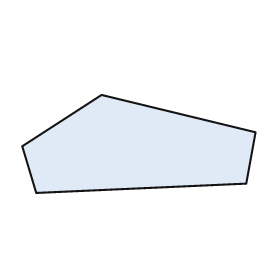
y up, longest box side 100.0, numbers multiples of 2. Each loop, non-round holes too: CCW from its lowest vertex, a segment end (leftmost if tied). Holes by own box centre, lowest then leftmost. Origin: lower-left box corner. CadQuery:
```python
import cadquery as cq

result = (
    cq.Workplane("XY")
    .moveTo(6.0, 0.0)
    .lineTo(96.0, 4.0)
    .lineTo(100.0, 26.0)
    .lineTo(34.0, 42.0)
    .lineTo(0.0, 20.0)
    .close()
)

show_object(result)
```